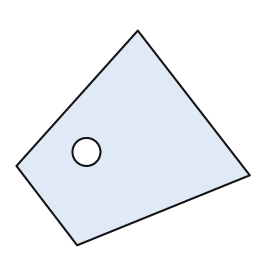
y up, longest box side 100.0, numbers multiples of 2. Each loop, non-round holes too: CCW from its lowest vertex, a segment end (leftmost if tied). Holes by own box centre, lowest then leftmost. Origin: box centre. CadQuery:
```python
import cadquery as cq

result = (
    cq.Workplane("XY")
    .moveTo(-24.0, -46.0)
    .lineTo(50.0, -16.0)
    .lineTo(2.0, 46.0)
    .lineTo(-50.0, -12.0)
    .close()
    .moveTo(-20.0, -6.0)
    .circle(6.0)
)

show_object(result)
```